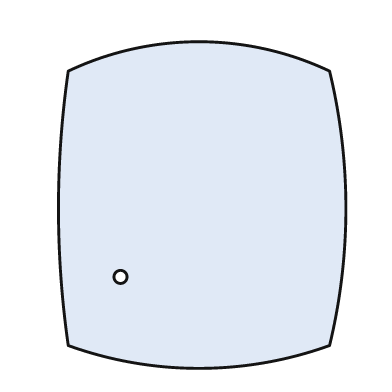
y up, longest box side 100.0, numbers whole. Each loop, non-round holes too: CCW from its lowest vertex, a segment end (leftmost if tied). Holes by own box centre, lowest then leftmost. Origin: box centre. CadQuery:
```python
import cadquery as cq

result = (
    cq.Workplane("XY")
    .moveTo(-41.0, -43.0)
    .threePointArc((-1.0, -50.0), (39.0, -43.0))
    .threePointArc((44.0, -1.0), (39.0, 41.0))
    .threePointArc((-1.0, 50.0), (-41.0, 41.0))
    .threePointArc((-44.0, -1.0), (-41.0, -43.0))
    .close()
    .moveTo(-25.0, -22.0)
    .circle(2.0)
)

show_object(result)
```